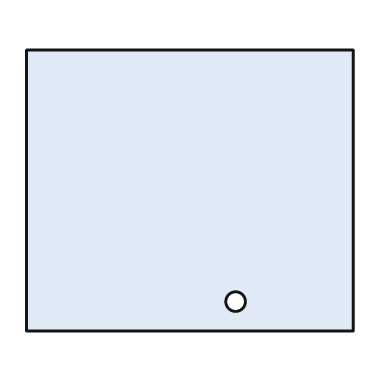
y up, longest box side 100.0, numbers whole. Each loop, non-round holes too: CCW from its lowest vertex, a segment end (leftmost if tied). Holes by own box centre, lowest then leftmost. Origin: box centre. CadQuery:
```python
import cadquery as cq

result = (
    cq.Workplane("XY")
    .moveTo(-50.0, -43.0)
    .lineTo(50.0, -43.0)
    .lineTo(50.0, 43.0)
    .lineTo(-50.0, 43.0)
    .close()
    .moveTo(14.0, -34.0)
    .circle(3.0)
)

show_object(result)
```